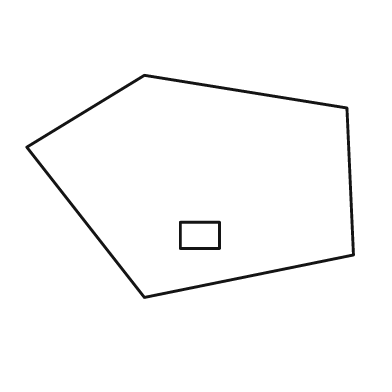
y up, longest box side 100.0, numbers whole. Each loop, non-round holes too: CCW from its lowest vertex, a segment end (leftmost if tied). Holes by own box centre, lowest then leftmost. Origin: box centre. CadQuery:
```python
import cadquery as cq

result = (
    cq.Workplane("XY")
    .moveTo(-14.0, -34.0)
    .lineTo(50.0, -21.0)
    .lineTo(48.0, 24.0)
    .lineTo(-14.0, 34.0)
    .lineTo(-50.0, 12.0)
    .close()
    .moveTo(-3.0, -19.0)
    .lineTo(9.0, -19.0)
    .lineTo(9.0, -11.0)
    .lineTo(-3.0, -11.0)
    .close()
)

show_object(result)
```